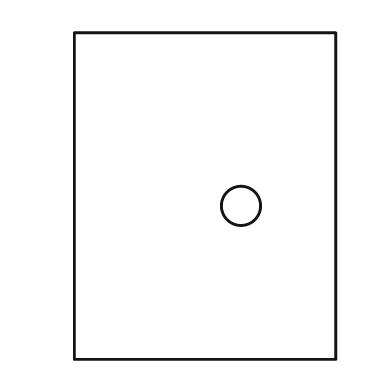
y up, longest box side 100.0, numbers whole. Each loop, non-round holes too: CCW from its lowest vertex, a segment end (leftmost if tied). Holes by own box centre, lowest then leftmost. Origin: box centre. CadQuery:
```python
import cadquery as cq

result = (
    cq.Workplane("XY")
    .moveTo(-40.0, -50.0)
    .lineTo(40.0, -50.0)
    .lineTo(40.0, 50.0)
    .lineTo(-40.0, 50.0)
    .close()
    .moveTo(11.0, -3.0)
    .circle(6.0)
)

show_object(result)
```